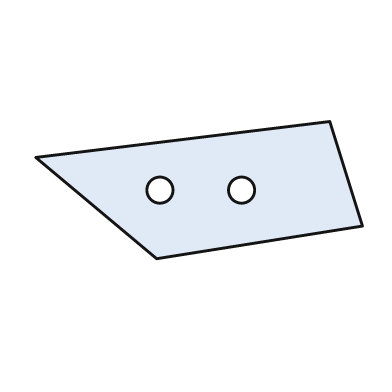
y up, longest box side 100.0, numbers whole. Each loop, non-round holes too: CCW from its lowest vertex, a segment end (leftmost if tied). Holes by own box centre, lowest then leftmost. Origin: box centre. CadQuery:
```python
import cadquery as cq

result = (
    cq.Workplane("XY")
    .moveTo(-13.0, -21.0)
    .lineTo(50.0, -11.0)
    .lineTo(40.0, 21.0)
    .lineTo(-50.0, 10.0)
    .close()
    .moveTo(-12.0, 0.0)
    .circle(4.0)
    .moveTo(13.0, 0.0)
    .circle(4.0)
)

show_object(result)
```